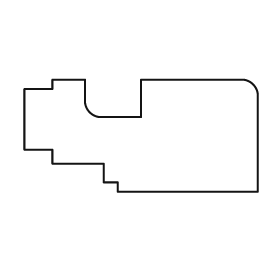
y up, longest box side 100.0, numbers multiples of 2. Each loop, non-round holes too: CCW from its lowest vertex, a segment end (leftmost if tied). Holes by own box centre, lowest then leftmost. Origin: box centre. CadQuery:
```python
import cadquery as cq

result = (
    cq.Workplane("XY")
    .moveTo(-10.0, -24.0)
    .lineTo(50.0, -24.0)
    .lineTo(50.0, 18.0)
    .threePointArc((48.0, 22.0), (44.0, 24.0))
    .lineTo(0.0, 24.0)
    .lineTo(0.0, 8.0)
    .lineTo(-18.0, 8.0)
    .threePointArc((-22.0, 10.0), (-24.0, 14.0))
    .lineTo(-24.0, 24.0)
    .lineTo(-38.0, 24.0)
    .lineTo(-38.0, 20.0)
    .lineTo(-50.0, 20.0)
    .lineTo(-50.0, -6.0)
    .lineTo(-38.0, -6.0)
    .lineTo(-38.0, -12.0)
    .lineTo(-16.0, -12.0)
    .lineTo(-16.0, -20.0)
    .lineTo(-10.0, -20.0)
    .close()
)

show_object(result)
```